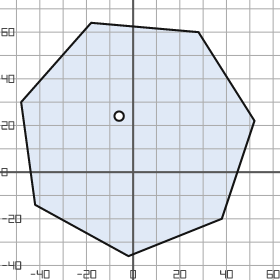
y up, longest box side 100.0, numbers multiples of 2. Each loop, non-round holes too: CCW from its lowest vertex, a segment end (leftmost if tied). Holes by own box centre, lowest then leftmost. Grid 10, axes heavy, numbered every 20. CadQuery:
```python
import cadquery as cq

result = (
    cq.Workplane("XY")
    .moveTo(-2.0, -36.0)
    .lineTo(38.0, -20.0)
    .lineTo(52.0, 22.0)
    .lineTo(28.0, 60.0)
    .lineTo(-18.0, 64.0)
    .lineTo(-48.0, 30.0)
    .lineTo(-42.0, -14.0)
    .close()
    .moveTo(-6.0, 24.0)
    .circle(2.0)
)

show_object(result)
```